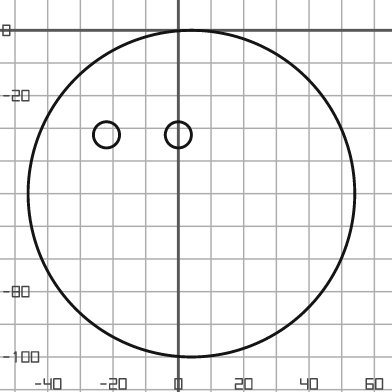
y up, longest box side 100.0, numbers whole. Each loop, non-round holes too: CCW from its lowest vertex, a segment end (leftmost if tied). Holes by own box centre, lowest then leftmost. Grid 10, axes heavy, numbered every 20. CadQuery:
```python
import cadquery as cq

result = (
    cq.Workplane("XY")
    .moveTo(4.0, -50.0)
    .circle(50.0)
    .moveTo(-22.0, -32.0)
    .circle(4.0)
    .moveTo(0.0, -32.0)
    .circle(4.0)
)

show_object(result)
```